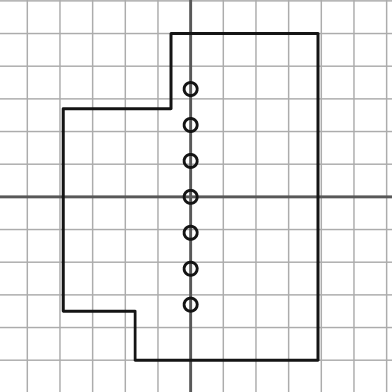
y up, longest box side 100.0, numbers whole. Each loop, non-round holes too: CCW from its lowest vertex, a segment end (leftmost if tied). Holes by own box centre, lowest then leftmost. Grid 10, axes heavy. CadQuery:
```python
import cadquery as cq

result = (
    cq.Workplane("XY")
    .moveTo(-17.0, -50.0)
    .lineTo(39.0, -50.0)
    .lineTo(39.0, 50.0)
    .lineTo(-6.0, 50.0)
    .lineTo(-6.0, 27.0)
    .lineTo(-39.0, 27.0)
    .lineTo(-39.0, -35.0)
    .lineTo(-17.0, -35.0)
    .close()
    .moveTo(0.0, -33.0)
    .circle(2.0)
    .moveTo(0.0, -22.0)
    .circle(2.0)
    .moveTo(0.0, -11.0)
    .circle(2.0)
    .moveTo(0.0, 0.0)
    .circle(2.0)
    .moveTo(0.0, 11.0)
    .circle(2.0)
    .moveTo(0.0, 22.0)
    .circle(2.0)
    .moveTo(0.0, 33.0)
    .circle(2.0)
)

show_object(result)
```